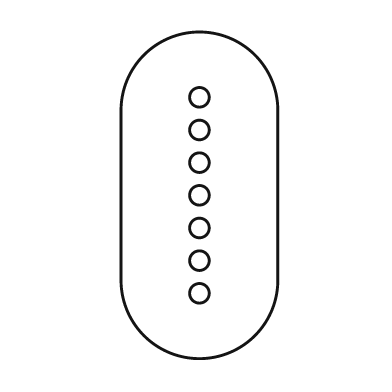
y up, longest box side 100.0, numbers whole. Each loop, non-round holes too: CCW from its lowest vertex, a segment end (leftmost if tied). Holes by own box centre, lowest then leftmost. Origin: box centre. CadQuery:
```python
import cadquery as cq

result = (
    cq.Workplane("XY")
    .moveTo(-24.0, -26.0)
    .threePointArc((0.0, -50.0), (24.0, -26.0))
    .lineTo(24.0, 26.0)
    .threePointArc((0.0, 50.0), (-24.0, 26.0))
    .close()
    .moveTo(0.0, -30.0)
    .circle(3.0)
    .moveTo(0.0, -20.0)
    .circle(3.0)
    .moveTo(0.0, -10.0)
    .circle(3.0)
    .moveTo(0.0, 0.0)
    .circle(3.0)
    .moveTo(0.0, 10.0)
    .circle(3.0)
    .moveTo(0.0, 20.0)
    .circle(3.0)
    .moveTo(0.0, 30.0)
    .circle(3.0)
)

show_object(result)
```